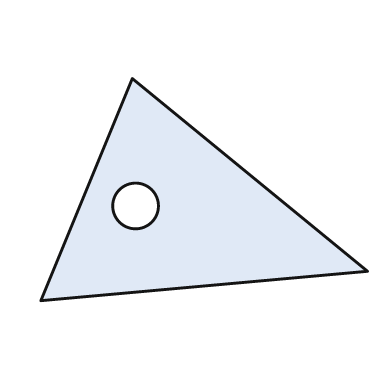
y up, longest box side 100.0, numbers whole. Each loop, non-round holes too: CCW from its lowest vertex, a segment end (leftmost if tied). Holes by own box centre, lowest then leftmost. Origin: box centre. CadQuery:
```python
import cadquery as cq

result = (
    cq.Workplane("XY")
    .moveTo(-50.0, -34.0)
    .lineTo(50.0, -25.0)
    .lineTo(-22.0, 34.0)
    .close()
    .moveTo(-21.0, -5.0)
    .circle(7.0)
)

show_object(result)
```